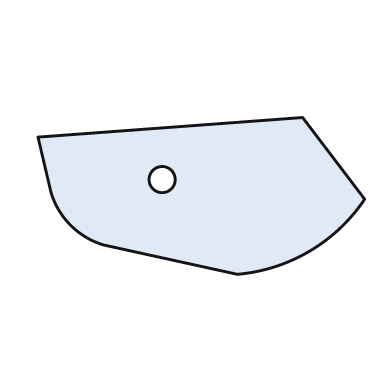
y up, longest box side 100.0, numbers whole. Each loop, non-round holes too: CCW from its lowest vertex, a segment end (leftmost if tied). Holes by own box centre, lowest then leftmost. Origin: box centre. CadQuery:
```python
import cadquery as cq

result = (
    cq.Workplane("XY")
    .moveTo(11.0, -24.0)
    .threePointArc((33.0, -17.0), (50.0, -1.0))
    .lineTo(31.0, 24.0)
    .lineTo(-50.0, 18.0)
    .lineTo(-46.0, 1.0)
    .threePointArc((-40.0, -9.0), (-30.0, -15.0))
    .close()
    .moveTo(-12.0, 5.0)
    .circle(4.0)
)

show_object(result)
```